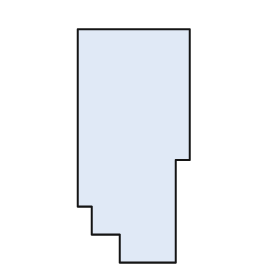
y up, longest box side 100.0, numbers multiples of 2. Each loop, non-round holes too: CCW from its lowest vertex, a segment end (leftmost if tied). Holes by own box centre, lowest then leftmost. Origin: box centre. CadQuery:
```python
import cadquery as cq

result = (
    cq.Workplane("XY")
    .moveTo(-6.0, -50.0)
    .lineTo(18.0, -50.0)
    .lineTo(18.0, -6.0)
    .lineTo(24.0, -6.0)
    .lineTo(24.0, 50.0)
    .lineTo(-24.0, 50.0)
    .lineTo(-24.0, -26.0)
    .lineTo(-18.0, -26.0)
    .lineTo(-18.0, -38.0)
    .lineTo(-6.0, -38.0)
    .close()
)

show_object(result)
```